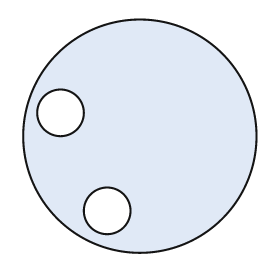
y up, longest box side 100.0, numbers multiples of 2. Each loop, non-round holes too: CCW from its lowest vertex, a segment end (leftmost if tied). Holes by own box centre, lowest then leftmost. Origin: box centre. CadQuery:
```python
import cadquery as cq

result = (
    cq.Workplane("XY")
    .moveTo(0.0, 0.0)
    .circle(50.0)
    .moveTo(-14.0, -32.0)
    .circle(10.0)
    .moveTo(-34.0, 10.0)
    .circle(10.0)
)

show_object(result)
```